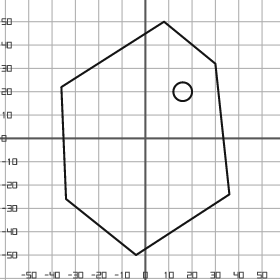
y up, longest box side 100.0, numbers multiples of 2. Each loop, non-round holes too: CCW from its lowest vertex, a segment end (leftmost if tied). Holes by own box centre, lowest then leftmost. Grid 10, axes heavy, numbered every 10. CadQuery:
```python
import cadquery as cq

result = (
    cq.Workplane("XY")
    .moveTo(-4.0, -50.0)
    .lineTo(36.0, -24.0)
    .lineTo(30.0, 32.0)
    .lineTo(8.0, 50.0)
    .lineTo(-36.0, 22.0)
    .lineTo(-34.0, -26.0)
    .close()
    .moveTo(16.0, 20.0)
    .circle(4.0)
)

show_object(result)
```